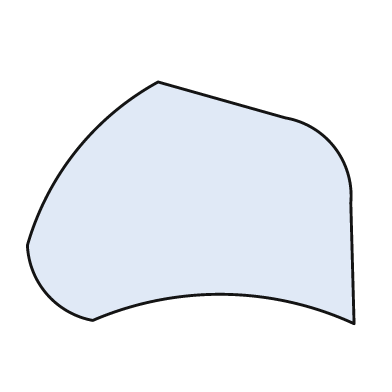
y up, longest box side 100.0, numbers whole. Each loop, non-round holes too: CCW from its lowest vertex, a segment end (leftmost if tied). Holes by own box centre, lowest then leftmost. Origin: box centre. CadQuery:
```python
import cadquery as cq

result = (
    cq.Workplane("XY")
    .moveTo(50.0, -37.0)
    .lineTo(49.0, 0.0)
    .threePointArc((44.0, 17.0), (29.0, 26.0))
    .lineTo(-10.0, 37.0)
    .threePointArc((-35.0, 16.0), (-50.0, -13.0))
    .threePointArc((-44.0, -28.0), (-30.0, -36.0))
    .threePointArc((10.0, -28.0), (50.0, -37.0))
    .close()
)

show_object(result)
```